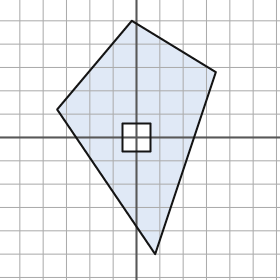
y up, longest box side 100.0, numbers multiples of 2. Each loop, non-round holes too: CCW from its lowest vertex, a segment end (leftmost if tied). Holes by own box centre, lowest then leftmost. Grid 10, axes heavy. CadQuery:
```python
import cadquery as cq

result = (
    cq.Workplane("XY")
    .moveTo(8.0, -50.0)
    .lineTo(34.0, 28.0)
    .lineTo(-2.0, 50.0)
    .lineTo(-34.0, 12.0)
    .close()
    .moveTo(-6.0, -6.0)
    .lineTo(6.0, -6.0)
    .lineTo(6.0, 6.0)
    .lineTo(-6.0, 6.0)
    .close()
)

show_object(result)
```